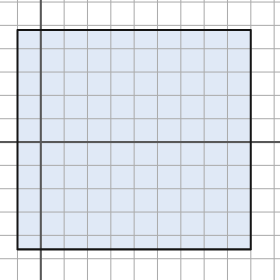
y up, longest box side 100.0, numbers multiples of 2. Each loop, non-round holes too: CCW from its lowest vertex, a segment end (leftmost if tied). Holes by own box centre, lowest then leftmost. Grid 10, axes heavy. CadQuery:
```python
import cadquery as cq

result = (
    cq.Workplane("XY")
    .moveTo(-10.0, -46.0)
    .lineTo(90.0, -46.0)
    .lineTo(90.0, 48.0)
    .lineTo(-10.0, 48.0)
    .close()
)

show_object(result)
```